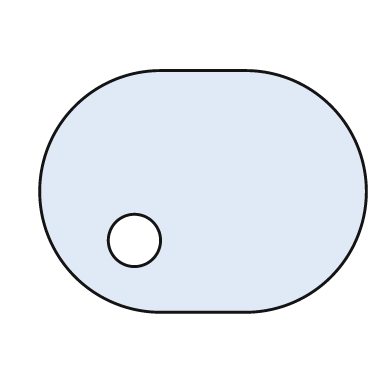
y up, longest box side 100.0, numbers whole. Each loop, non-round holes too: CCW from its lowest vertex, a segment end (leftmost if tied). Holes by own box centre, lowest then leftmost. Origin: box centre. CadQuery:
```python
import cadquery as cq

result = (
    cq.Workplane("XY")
    .moveTo(-13.0, -37.0)
    .lineTo(13.0, -37.0)
    .threePointArc((50.0, 0.0), (13.0, 37.0))
    .lineTo(-13.0, 37.0)
    .threePointArc((-50.0, 0.0), (-13.0, -37.0))
    .close()
    .moveTo(-21.0, -15.0)
    .circle(8.0)
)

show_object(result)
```